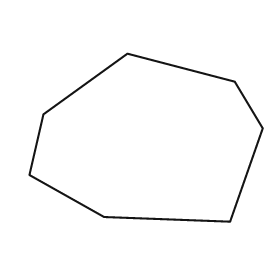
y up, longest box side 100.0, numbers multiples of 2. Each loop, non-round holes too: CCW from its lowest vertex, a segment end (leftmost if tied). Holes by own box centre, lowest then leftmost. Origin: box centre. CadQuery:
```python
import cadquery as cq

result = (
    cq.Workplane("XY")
    .moveTo(36.0, -36.0)
    .lineTo(50.0, 4.0)
    .lineTo(38.0, 24.0)
    .lineTo(-8.0, 36.0)
    .lineTo(-44.0, 10.0)
    .lineTo(-50.0, -16.0)
    .lineTo(-18.0, -34.0)
    .close()
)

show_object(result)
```